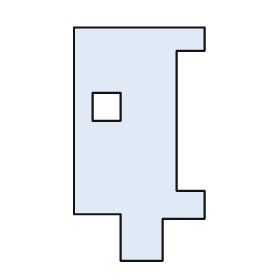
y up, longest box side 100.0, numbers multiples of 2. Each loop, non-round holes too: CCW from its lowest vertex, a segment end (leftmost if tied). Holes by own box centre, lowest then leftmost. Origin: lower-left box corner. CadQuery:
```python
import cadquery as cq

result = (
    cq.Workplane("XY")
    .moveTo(20.0, 0.0)
    .lineTo(38.0, 0.0)
    .lineTo(38.0, 18.0)
    .lineTo(56.0, 18.0)
    .lineTo(56.0, 30.0)
    .lineTo(44.0, 30.0)
    .lineTo(44.0, 90.0)
    .lineTo(56.0, 90.0)
    .lineTo(56.0, 100.0)
    .lineTo(0.0, 100.0)
    .lineTo(0.0, 20.0)
    .lineTo(20.0, 20.0)
    .close()
    .moveTo(8.0, 60.0)
    .lineTo(20.0, 60.0)
    .lineTo(20.0, 72.0)
    .lineTo(8.0, 72.0)
    .close()
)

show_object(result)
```